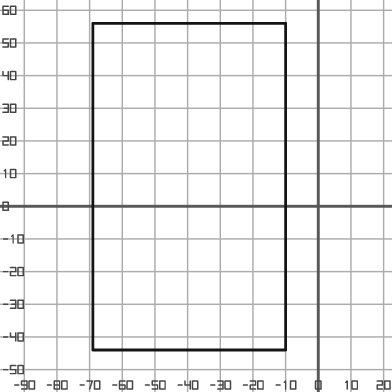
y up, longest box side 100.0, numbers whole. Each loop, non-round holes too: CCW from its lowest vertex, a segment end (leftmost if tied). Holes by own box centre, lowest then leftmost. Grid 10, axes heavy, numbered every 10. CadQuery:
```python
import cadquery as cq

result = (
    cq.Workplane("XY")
    .moveTo(-69.0, -44.0)
    .lineTo(-10.0, -44.0)
    .lineTo(-10.0, 56.0)
    .lineTo(-69.0, 56.0)
    .close()
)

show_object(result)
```